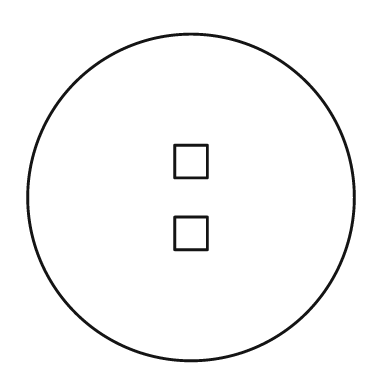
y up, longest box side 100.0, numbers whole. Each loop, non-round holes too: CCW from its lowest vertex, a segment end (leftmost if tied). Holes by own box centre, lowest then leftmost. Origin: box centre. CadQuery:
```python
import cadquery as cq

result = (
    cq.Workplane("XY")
    .moveTo(0.0, 0.0)
    .circle(50.0)
    .moveTo(-5.0, -16.0)
    .lineTo(5.0, -16.0)
    .lineTo(5.0, -6.0)
    .lineTo(-5.0, -6.0)
    .close()
    .moveTo(-5.0, 6.0)
    .lineTo(5.0, 6.0)
    .lineTo(5.0, 16.0)
    .lineTo(-5.0, 16.0)
    .close()
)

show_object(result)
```